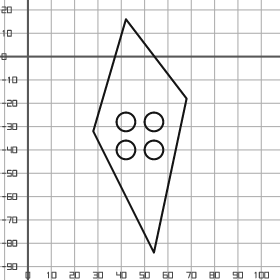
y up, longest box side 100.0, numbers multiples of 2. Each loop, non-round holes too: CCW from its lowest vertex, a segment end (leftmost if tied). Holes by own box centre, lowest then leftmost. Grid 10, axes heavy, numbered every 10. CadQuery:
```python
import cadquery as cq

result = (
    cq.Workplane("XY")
    .moveTo(54.0, -84.0)
    .lineTo(68.0, -18.0)
    .lineTo(42.0, 16.0)
    .lineTo(28.0, -32.0)
    .close()
    .moveTo(42.0, -40.0)
    .circle(4.0)
    .moveTo(54.0, -40.0)
    .circle(4.0)
    .moveTo(42.0, -28.0)
    .circle(4.0)
    .moveTo(54.0, -28.0)
    .circle(4.0)
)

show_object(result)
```